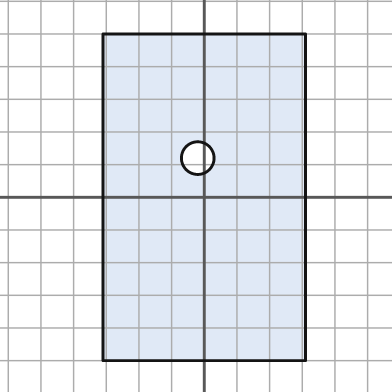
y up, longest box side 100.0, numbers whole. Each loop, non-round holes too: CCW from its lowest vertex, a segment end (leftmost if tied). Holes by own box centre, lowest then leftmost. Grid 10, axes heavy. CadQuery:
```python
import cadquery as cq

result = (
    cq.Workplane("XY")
    .moveTo(-31.0, -50.0)
    .lineTo(31.0, -50.0)
    .lineTo(31.0, 50.0)
    .lineTo(-31.0, 50.0)
    .close()
    .moveTo(-2.0, 12.0)
    .circle(5.0)
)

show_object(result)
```